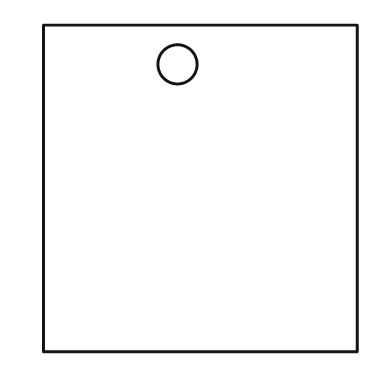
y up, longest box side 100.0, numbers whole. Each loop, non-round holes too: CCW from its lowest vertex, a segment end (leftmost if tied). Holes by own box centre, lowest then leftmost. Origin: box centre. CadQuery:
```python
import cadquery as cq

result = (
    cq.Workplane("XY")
    .moveTo(-48.0, -50.0)
    .lineTo(48.0, -50.0)
    .lineTo(48.0, 50.0)
    .lineTo(-48.0, 50.0)
    .close()
    .moveTo(-7.0, 38.0)
    .circle(6.0)
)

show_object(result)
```